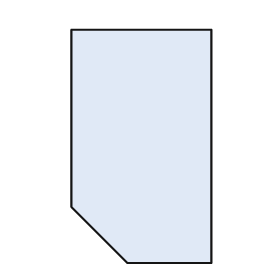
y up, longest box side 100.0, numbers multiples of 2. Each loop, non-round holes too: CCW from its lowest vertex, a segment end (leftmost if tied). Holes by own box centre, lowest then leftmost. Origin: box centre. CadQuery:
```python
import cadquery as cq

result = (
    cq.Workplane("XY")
    .moveTo(-6.0, -50.0)
    .lineTo(30.0, -50.0)
    .lineTo(30.0, 50.0)
    .lineTo(-30.0, 50.0)
    .lineTo(-30.0, -26.0)
    .close()
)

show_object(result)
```